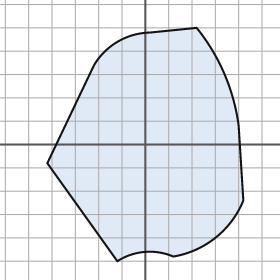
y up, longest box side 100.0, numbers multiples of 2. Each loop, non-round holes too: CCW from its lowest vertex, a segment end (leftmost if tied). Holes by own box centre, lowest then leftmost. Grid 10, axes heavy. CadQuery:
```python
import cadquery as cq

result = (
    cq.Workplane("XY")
    .moveTo(-12.0, -50.0)
    .threePointArc((0.0, -46.0), (12.0, -48.0))
    .threePointArc((30.0, -40.0), (42.0, -24.0))
    .lineTo(40.0, 8.0)
    .threePointArc((34.0, 30.0), (22.0, 50.0))
    .lineTo(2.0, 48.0)
    .threePointArc((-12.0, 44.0), (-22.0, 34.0))
    .lineTo(-42.0, -8.0)
    .close()
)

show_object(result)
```